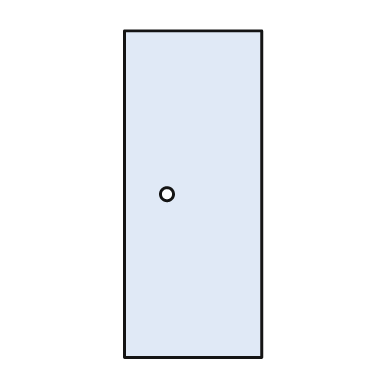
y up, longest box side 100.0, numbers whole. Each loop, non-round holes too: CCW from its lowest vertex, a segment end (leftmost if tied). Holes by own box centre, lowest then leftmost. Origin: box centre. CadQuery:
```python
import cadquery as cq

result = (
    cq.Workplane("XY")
    .moveTo(-21.0, -50.0)
    .lineTo(21.0, -50.0)
    .lineTo(21.0, 50.0)
    .lineTo(-21.0, 50.0)
    .close()
    .moveTo(-8.0, 0.0)
    .circle(2.0)
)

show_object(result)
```